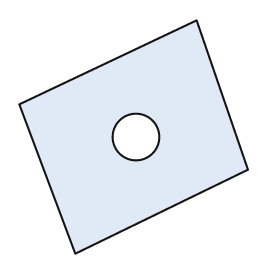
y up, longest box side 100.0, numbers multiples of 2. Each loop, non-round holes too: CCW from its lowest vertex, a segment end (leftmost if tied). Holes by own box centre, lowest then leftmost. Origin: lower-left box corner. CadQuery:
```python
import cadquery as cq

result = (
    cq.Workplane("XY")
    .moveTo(24.0, 0.0)
    .lineTo(98.0, 36.0)
    .lineTo(76.0, 100.0)
    .lineTo(0.0, 64.0)
    .close()
    .moveTo(50.0, 50.0)
    .circle(10.0)
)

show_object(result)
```